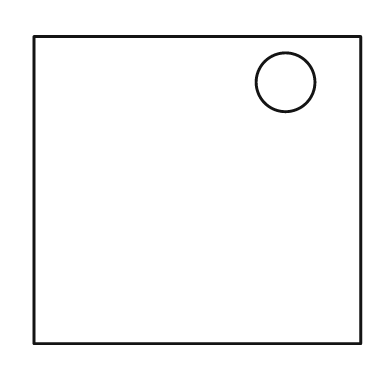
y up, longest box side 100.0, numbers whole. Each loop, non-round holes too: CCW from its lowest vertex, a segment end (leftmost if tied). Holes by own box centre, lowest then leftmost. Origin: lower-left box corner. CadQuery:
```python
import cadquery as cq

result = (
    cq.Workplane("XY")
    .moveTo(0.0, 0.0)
    .lineTo(100.0, 0.0)
    .lineTo(100.0, 94.0)
    .lineTo(0.0, 94.0)
    .close()
    .moveTo(77.0, 80.0)
    .circle(9.0)
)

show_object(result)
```